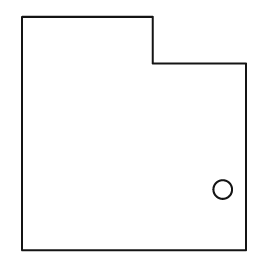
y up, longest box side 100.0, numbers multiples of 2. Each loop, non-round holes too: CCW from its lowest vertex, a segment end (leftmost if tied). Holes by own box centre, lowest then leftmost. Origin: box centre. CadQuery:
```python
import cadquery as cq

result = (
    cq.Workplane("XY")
    .moveTo(-48.0, -50.0)
    .lineTo(48.0, -50.0)
    .lineTo(48.0, 30.0)
    .lineTo(8.0, 30.0)
    .lineTo(8.0, 50.0)
    .lineTo(-48.0, 50.0)
    .close()
    .moveTo(38.0, -24.0)
    .circle(4.0)
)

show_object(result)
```